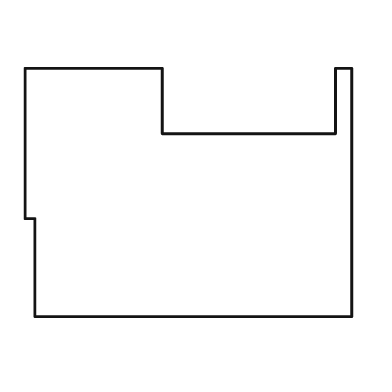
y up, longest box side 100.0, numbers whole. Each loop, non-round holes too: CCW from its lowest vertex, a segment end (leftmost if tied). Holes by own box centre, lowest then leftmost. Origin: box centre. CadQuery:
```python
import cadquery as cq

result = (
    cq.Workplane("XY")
    .moveTo(-47.0, -38.0)
    .lineTo(50.0, -38.0)
    .lineTo(50.0, 38.0)
    .lineTo(45.0, 38.0)
    .lineTo(45.0, 18.0)
    .lineTo(-8.0, 18.0)
    .lineTo(-8.0, 38.0)
    .lineTo(-50.0, 38.0)
    .lineTo(-50.0, -8.0)
    .lineTo(-47.0, -8.0)
    .close()
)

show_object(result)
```